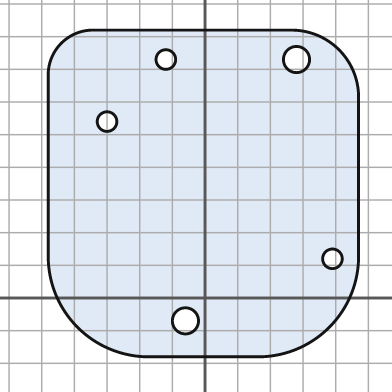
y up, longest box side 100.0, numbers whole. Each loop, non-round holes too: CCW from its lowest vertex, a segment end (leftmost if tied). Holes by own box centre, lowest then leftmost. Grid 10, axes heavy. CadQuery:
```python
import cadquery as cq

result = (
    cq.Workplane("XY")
    .moveTo(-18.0, -18.0)
    .lineTo(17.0, -18.0)
    .threePointArc((38.0, -9.0), (47.0, 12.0))
    .lineTo(47.0, 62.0)
    .threePointArc((41.0, 76.0), (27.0, 82.0))
    .lineTo(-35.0, 82.0)
    .threePointArc((-44.0, 78.0), (-48.0, 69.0))
    .lineTo(-48.0, 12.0)
    .threePointArc((-39.0, -9.0), (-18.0, -18.0))
    .close()
    .moveTo(-6.0, -7.0)
    .circle(4.0)
    .moveTo(39.0, 12.0)
    .circle(3.0)
    .moveTo(-30.0, 54.0)
    .circle(3.0)
    .moveTo(-12.0, 73.0)
    .circle(3.0)
    .moveTo(28.0, 73.0)
    .circle(4.0)
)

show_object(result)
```